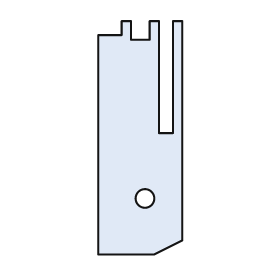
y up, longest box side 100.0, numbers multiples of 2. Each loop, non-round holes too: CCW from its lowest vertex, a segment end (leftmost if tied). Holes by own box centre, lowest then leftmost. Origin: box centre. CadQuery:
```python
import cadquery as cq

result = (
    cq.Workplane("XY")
    .moveTo(-18.0, -50.0)
    .lineTo(6.0, -50.0)
    .lineTo(18.0, -44.0)
    .lineTo(18.0, 50.0)
    .lineTo(14.0, 50.0)
    .lineTo(14.0, 2.0)
    .lineTo(8.0, 2.0)
    .lineTo(8.0, 50.0)
    .lineTo(4.0, 50.0)
    .lineTo(4.0, 42.0)
    .lineTo(-4.0, 42.0)
    .lineTo(-4.0, 50.0)
    .lineTo(-8.0, 50.0)
    .lineTo(-8.0, 44.0)
    .lineTo(-18.0, 44.0)
    .close()
    .moveTo(2.0, -26.0)
    .circle(4.0)
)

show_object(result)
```